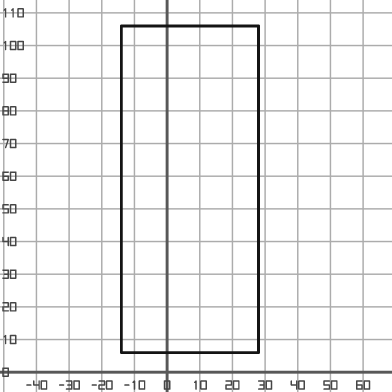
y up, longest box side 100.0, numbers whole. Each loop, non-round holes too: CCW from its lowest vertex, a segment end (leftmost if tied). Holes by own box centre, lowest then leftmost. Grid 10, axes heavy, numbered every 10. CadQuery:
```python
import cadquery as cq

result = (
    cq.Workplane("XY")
    .moveTo(-14.0, 6.0)
    .lineTo(28.0, 6.0)
    .lineTo(28.0, 106.0)
    .lineTo(-14.0, 106.0)
    .close()
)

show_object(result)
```